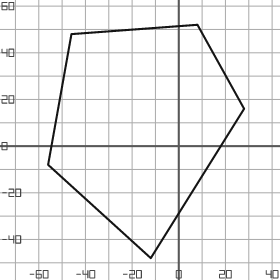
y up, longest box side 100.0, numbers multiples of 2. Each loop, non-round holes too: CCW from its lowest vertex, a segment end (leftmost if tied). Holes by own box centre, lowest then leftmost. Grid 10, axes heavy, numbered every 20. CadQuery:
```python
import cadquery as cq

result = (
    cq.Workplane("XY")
    .moveTo(-12.0, -48.0)
    .lineTo(28.0, 16.0)
    .lineTo(8.0, 52.0)
    .lineTo(-46.0, 48.0)
    .lineTo(-56.0, -8.0)
    .close()
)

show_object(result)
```